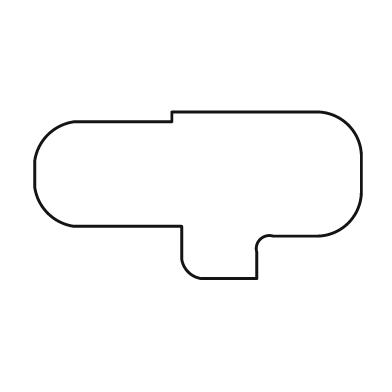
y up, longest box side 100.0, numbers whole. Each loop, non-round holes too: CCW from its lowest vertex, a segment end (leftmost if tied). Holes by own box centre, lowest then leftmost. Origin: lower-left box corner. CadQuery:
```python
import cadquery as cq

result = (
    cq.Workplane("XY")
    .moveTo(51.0, 0.0)
    .lineTo(68.0, 0.0)
    .lineTo(68.0, 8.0)
    .threePointArc((69.0, 12.0), (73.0, 13.0))
    .lineTo(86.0, 13.0)
    .threePointArc((96.0, 17.0), (100.0, 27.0))
    .lineTo(100.0, 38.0)
    .threePointArc((96.0, 47.0), (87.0, 51.0))
    .lineTo(42.0, 51.0)
    .lineTo(42.0, 48.0)
    .lineTo(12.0, 48.0)
    .threePointArc((4.0, 44.0), (0.0, 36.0))
    .lineTo(0.0, 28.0)
    .threePointArc((4.0, 20.0), (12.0, 16.0))
    .lineTo(45.0, 16.0)
    .lineTo(45.0, 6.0)
    .threePointArc((47.0, 2.0), (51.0, 0.0))
    .close()
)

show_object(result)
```